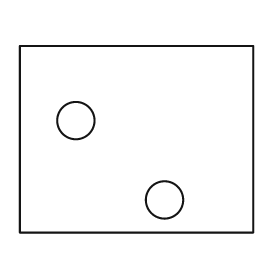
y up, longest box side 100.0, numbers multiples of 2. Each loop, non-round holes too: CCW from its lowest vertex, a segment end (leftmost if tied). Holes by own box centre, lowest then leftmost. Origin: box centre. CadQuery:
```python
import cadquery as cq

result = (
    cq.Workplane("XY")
    .moveTo(-50.0, -40.0)
    .lineTo(50.0, -40.0)
    .lineTo(50.0, 40.0)
    .lineTo(-50.0, 40.0)
    .close()
    .moveTo(12.0, -26.0)
    .circle(8.0)
    .moveTo(-26.0, 8.0)
    .circle(8.0)
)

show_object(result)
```